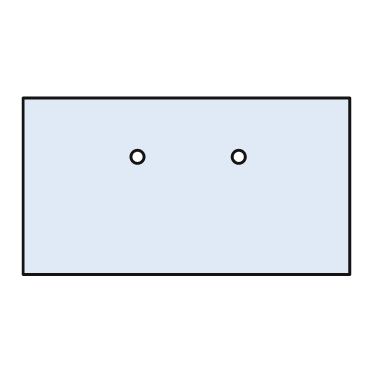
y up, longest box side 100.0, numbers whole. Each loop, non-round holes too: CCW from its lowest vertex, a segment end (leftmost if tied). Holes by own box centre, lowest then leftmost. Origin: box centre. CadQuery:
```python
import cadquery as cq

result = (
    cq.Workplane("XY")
    .moveTo(-50.0, -27.0)
    .lineTo(50.0, -27.0)
    .lineTo(50.0, 27.0)
    .lineTo(-50.0, 27.0)
    .close()
    .moveTo(-15.0, 9.0)
    .circle(2.0)
    .moveTo(16.0, 9.0)
    .circle(2.0)
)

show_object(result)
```